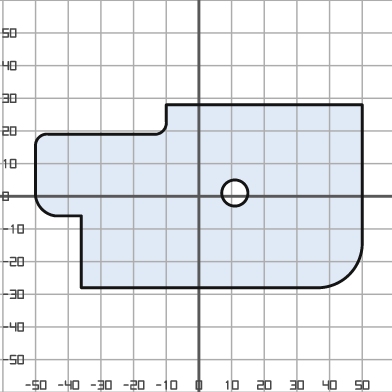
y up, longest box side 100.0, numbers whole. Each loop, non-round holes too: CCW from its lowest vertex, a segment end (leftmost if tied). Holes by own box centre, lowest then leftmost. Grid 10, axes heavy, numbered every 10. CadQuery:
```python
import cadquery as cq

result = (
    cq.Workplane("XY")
    .moveTo(-36.0, -28.0)
    .lineTo(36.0, -28.0)
    .threePointArc((46.0, -24.0), (50.0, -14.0))
    .lineTo(50.0, 28.0)
    .lineTo(-10.0, 28.0)
    .lineTo(-10.0, 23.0)
    .threePointArc((-11.0, 20.0), (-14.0, 19.0))
    .lineTo(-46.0, 19.0)
    .threePointArc((-49.0, 18.0), (-50.0, 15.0))
    .lineTo(-50.0, 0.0)
    .threePointArc((-48.0, -4.0), (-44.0, -6.0))
    .lineTo(-36.0, -6.0)
    .close()
    .moveTo(11.0, 1.0)
    .circle(4.0)
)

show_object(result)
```